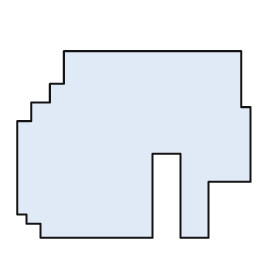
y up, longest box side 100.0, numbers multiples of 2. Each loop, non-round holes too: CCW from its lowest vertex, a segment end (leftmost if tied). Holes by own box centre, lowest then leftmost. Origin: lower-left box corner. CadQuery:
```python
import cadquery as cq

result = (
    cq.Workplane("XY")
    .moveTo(10.0, 0.0)
    .lineTo(58.0, 0.0)
    .lineTo(58.0, 36.0)
    .lineTo(70.0, 36.0)
    .lineTo(70.0, 0.0)
    .lineTo(82.0, 0.0)
    .lineTo(82.0, 24.0)
    .lineTo(100.0, 24.0)
    .lineTo(100.0, 56.0)
    .lineTo(96.0, 56.0)
    .lineTo(96.0, 80.0)
    .lineTo(20.0, 80.0)
    .lineTo(20.0, 66.0)
    .lineTo(14.0, 66.0)
    .lineTo(14.0, 58.0)
    .lineTo(6.0, 58.0)
    .lineTo(6.0, 50.0)
    .lineTo(0.0, 50.0)
    .lineTo(0.0, 10.0)
    .lineTo(4.0, 10.0)
    .lineTo(4.0, 6.0)
    .lineTo(10.0, 6.0)
    .close()
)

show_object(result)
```